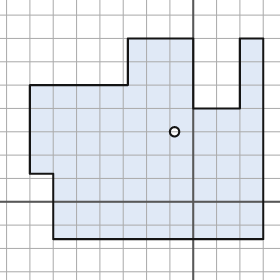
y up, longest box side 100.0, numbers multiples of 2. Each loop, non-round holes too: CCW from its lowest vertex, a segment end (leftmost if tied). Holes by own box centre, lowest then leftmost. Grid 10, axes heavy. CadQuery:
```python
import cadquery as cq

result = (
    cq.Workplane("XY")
    .moveTo(-60.0, -16.0)
    .lineTo(30.0, -16.0)
    .lineTo(30.0, 70.0)
    .lineTo(20.0, 70.0)
    .lineTo(20.0, 40.0)
    .lineTo(0.0, 40.0)
    .lineTo(0.0, 70.0)
    .lineTo(-28.0, 70.0)
    .lineTo(-28.0, 50.0)
    .lineTo(-70.0, 50.0)
    .lineTo(-70.0, 12.0)
    .lineTo(-60.0, 12.0)
    .close()
    .moveTo(-8.0, 30.0)
    .circle(2.0)
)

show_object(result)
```